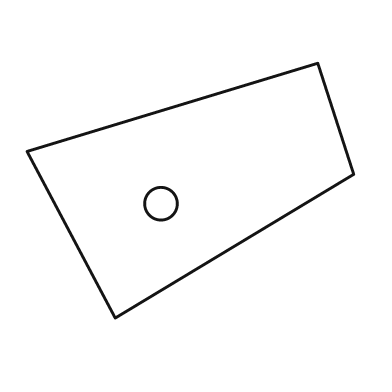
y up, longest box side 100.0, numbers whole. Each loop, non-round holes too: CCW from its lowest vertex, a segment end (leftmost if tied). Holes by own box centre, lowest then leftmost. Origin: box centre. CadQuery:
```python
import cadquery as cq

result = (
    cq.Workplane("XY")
    .moveTo(-23.0, -39.0)
    .lineTo(50.0, 5.0)
    .lineTo(39.0, 39.0)
    .lineTo(-50.0, 12.0)
    .close()
    .moveTo(-9.0, -4.0)
    .circle(5.0)
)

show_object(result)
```